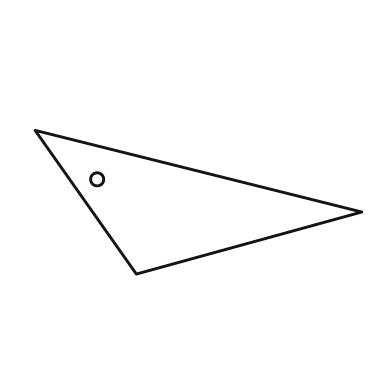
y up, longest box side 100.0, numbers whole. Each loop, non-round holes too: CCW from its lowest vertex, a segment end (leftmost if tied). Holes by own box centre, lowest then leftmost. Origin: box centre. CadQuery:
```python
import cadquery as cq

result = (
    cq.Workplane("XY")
    .moveTo(-19.0, -22.0)
    .lineTo(50.0, -3.0)
    .lineTo(-50.0, 22.0)
    .close()
    .moveTo(-31.0, 7.0)
    .circle(2.0)
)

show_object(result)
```